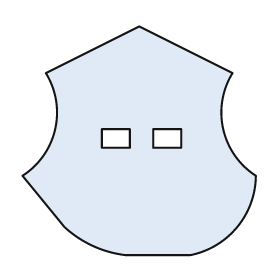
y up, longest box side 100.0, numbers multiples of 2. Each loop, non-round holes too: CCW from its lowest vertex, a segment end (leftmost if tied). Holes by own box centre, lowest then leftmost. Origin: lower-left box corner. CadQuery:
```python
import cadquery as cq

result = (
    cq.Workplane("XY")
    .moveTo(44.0, 0.0)
    .lineTo(72.0, 0.0)
    .threePointArc((92.0, 12.0), (100.0, 34.0))
    .threePointArc((86.0, 54.0), (90.0, 78.0))
    .lineTo(50.0, 98.0)
    .lineTo(10.0, 78.0)
    .threePointArc((14.0, 54.0), (0.0, 34.0))
    .lineTo(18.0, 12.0)
    .threePointArc((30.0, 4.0), (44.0, 0.0))
    .close()
    .moveTo(34.0, 46.0)
    .lineTo(46.0, 46.0)
    .lineTo(46.0, 54.0)
    .lineTo(34.0, 54.0)
    .close()
    .moveTo(56.0, 46.0)
    .lineTo(68.0, 46.0)
    .lineTo(68.0, 54.0)
    .lineTo(56.0, 54.0)
    .close()
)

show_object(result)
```